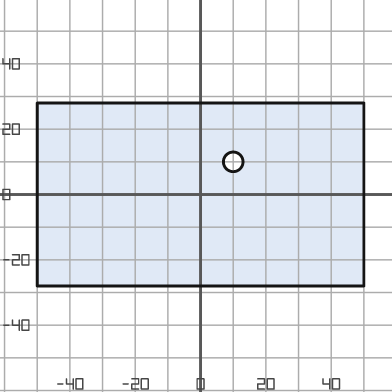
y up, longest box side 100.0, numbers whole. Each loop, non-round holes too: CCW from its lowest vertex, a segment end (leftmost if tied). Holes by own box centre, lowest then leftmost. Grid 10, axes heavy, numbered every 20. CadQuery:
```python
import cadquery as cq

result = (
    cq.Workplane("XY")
    .moveTo(-50.0, -28.0)
    .lineTo(50.0, -28.0)
    .lineTo(50.0, 28.0)
    .lineTo(-50.0, 28.0)
    .close()
    .moveTo(10.0, 10.0)
    .circle(3.0)
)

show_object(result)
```